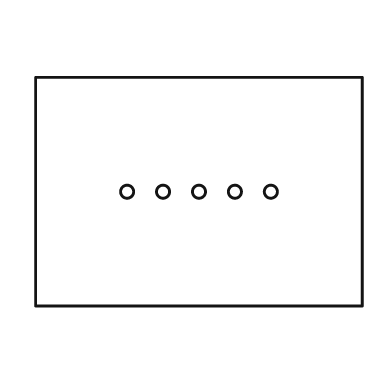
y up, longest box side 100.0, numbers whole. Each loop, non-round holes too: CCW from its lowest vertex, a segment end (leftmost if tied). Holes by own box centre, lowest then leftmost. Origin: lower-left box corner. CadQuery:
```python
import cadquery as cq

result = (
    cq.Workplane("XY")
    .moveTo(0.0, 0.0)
    .lineTo(100.0, 0.0)
    .lineTo(100.0, 70.0)
    .lineTo(0.0, 70.0)
    .close()
    .moveTo(28.0, 35.0)
    .circle(2.0)
    .moveTo(39.0, 35.0)
    .circle(2.0)
    .moveTo(50.0, 35.0)
    .circle(2.0)
    .moveTo(61.0, 35.0)
    .circle(2.0)
    .moveTo(72.0, 35.0)
    .circle(2.0)
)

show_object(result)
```